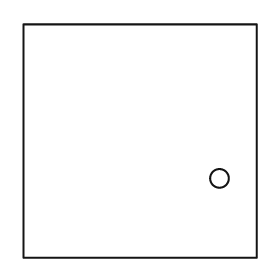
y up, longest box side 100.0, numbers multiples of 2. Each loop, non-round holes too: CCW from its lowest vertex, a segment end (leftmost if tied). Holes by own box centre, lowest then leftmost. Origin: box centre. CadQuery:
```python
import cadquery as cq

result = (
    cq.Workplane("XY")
    .moveTo(-50.0, -50.0)
    .lineTo(50.0, -50.0)
    .lineTo(50.0, 50.0)
    .lineTo(-50.0, 50.0)
    .close()
    .moveTo(34.0, -16.0)
    .circle(4.0)
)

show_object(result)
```